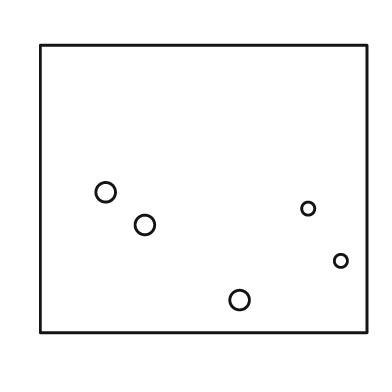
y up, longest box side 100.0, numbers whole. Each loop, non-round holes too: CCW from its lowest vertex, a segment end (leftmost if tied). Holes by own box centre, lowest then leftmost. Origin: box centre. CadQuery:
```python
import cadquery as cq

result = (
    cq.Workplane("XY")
    .moveTo(-50.0, -44.0)
    .lineTo(50.0, -44.0)
    .lineTo(50.0, 44.0)
    .lineTo(-50.0, 44.0)
    .close()
    .moveTo(11.0, -34.0)
    .circle(3.0)
    .moveTo(42.0, -22.0)
    .circle(2.0)
    .moveTo(-18.0, -11.0)
    .circle(3.0)
    .moveTo(32.0, -6.0)
    .circle(2.0)
    .moveTo(-30.0, -1.0)
    .circle(3.0)
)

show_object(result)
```